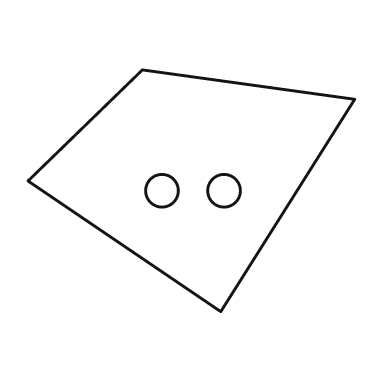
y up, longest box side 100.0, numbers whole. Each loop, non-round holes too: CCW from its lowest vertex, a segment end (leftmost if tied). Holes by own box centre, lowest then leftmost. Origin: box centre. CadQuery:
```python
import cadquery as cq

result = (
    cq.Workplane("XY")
    .moveTo(9.0, -37.0)
    .lineTo(50.0, 28.0)
    .lineTo(-15.0, 37.0)
    .lineTo(-50.0, 3.0)
    .close()
    .moveTo(-9.0, 0.0)
    .circle(5.0)
    .moveTo(10.0, 0.0)
    .circle(5.0)
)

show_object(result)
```